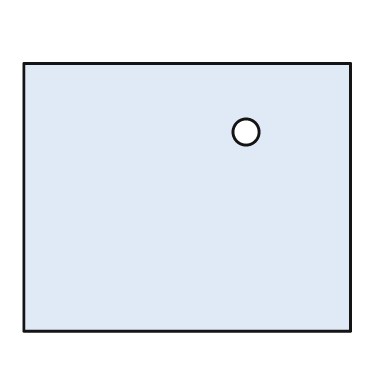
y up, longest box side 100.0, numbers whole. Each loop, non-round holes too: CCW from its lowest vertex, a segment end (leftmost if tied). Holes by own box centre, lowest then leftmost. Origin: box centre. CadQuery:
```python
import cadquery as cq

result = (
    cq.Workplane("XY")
    .moveTo(-50.0, -41.0)
    .lineTo(50.0, -41.0)
    .lineTo(50.0, 41.0)
    .lineTo(-50.0, 41.0)
    .close()
    .moveTo(18.0, 20.0)
    .circle(4.0)
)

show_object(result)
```